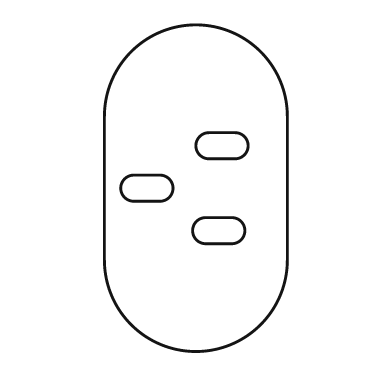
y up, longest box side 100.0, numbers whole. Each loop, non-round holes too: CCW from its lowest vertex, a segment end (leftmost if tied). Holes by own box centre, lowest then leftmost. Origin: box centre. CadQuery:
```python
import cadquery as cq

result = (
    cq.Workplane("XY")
    .moveTo(-28.0, -22.0)
    .threePointArc((0.0, -50.0), (28.0, -22.0))
    .lineTo(28.0, 22.0)
    .threePointArc((0.0, 50.0), (-28.0, 22.0))
    .close()
    .moveTo(3.0, -17.0)
    .lineTo(11.0, -17.0)
    .threePointArc((15.0, -13.0), (11.0, -9.0))
    .lineTo(3.0, -9.0)
    .threePointArc((-1.0, -13.0), (3.0, -17.0))
    .close()
    .moveTo(-19.0, -4.0)
    .lineTo(-11.0, -4.0)
    .threePointArc((-7.0, 0.0), (-11.0, 4.0))
    .lineTo(-19.0, 4.0)
    .threePointArc((-23.0, 0.0), (-19.0, -4.0))
    .close()
    .moveTo(4.0, 9.0)
    .lineTo(12.0, 9.0)
    .threePointArc((16.0, 13.0), (12.0, 17.0))
    .lineTo(4.0, 17.0)
    .threePointArc((0.0, 13.0), (4.0, 9.0))
    .close()
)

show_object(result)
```